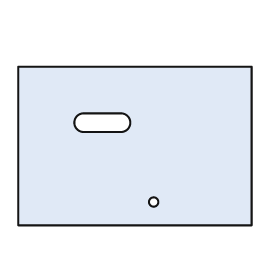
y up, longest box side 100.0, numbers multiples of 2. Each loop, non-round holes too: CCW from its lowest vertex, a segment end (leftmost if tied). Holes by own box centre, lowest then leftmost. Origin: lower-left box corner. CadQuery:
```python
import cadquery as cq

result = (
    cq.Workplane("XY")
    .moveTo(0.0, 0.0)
    .lineTo(100.0, 0.0)
    .lineTo(100.0, 68.0)
    .lineTo(0.0, 68.0)
    .close()
    .moveTo(58.0, 10.0)
    .circle(2.0)
    .moveTo(28.0, 40.0)
    .lineTo(44.0, 40.0)
    .threePointArc((48.0, 44.0), (44.0, 48.0))
    .lineTo(28.0, 48.0)
    .threePointArc((24.0, 44.0), (28.0, 40.0))
    .close()
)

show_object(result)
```